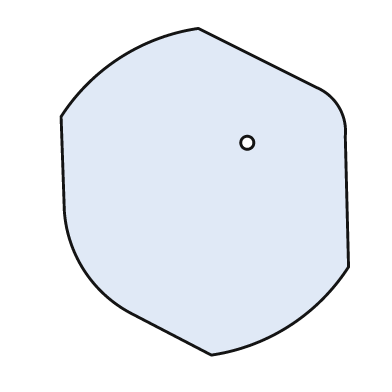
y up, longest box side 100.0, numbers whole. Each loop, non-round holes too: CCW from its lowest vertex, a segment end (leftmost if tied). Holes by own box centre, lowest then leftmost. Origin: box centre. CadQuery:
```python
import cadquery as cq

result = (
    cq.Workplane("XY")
    .moveTo(2.0, -50.0)
    .threePointArc((26.0, -41.0), (44.0, -23.0))
    .lineTo(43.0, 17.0)
    .threePointArc((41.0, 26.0), (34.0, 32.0))
    .lineTo(-2.0, 50.0)
    .threePointArc((-26.0, 41.0), (-44.0, 23.0))
    .lineTo(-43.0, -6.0)
    .threePointArc((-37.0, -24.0), (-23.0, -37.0))
    .close()
    .moveTo(13.0, 15.0)
    .circle(2.0)
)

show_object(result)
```